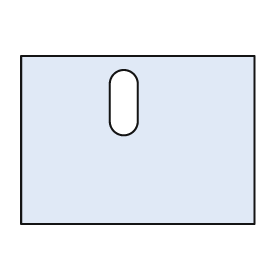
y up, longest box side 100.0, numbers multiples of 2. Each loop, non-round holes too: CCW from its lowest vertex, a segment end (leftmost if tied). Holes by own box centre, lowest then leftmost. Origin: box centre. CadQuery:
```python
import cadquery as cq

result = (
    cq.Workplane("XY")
    .moveTo(-50.0, -36.0)
    .lineTo(50.0, -36.0)
    .lineTo(50.0, 36.0)
    .lineTo(-50.0, 36.0)
    .close()
    .moveTo(-12.0, 8.0)
    .threePointArc((-6.0, 2.0), (0.0, 8.0))
    .lineTo(0.0, 24.0)
    .threePointArc((-6.0, 30.0), (-12.0, 24.0))
    .close()
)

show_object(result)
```